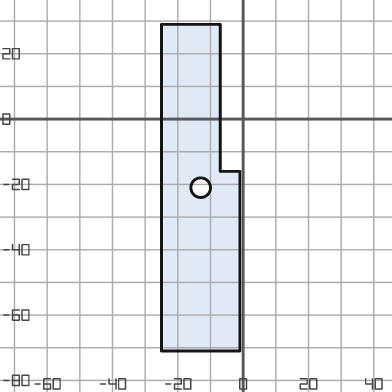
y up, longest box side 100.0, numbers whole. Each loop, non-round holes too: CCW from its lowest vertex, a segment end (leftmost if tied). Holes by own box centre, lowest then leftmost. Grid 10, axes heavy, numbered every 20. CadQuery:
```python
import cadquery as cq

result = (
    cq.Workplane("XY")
    .moveTo(-25.0, -71.0)
    .lineTo(-1.0, -71.0)
    .lineTo(-1.0, -16.0)
    .lineTo(-7.0, -16.0)
    .lineTo(-7.0, 29.0)
    .lineTo(-25.0, 29.0)
    .close()
    .moveTo(-13.0, -21.0)
    .circle(3.0)
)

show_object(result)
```